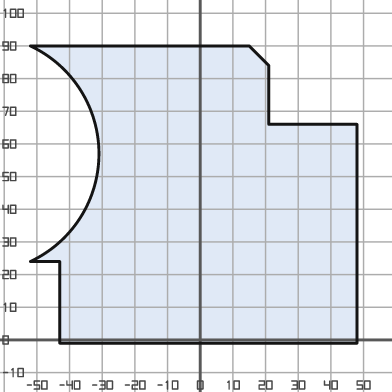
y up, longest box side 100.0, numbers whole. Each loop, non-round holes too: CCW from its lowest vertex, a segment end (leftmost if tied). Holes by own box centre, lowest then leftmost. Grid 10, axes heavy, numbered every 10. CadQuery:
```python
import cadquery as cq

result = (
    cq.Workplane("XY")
    .moveTo(-43.0, -1.0)
    .lineTo(48.0, -1.0)
    .lineTo(48.0, 66.0)
    .lineTo(21.0, 66.0)
    .lineTo(21.0, 84.0)
    .lineTo(15.0, 90.0)
    .lineTo(-52.0, 90.0)
    .threePointArc((-31.0, 57.0), (-52.0, 24.0))
    .lineTo(-43.0, 24.0)
    .close()
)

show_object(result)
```